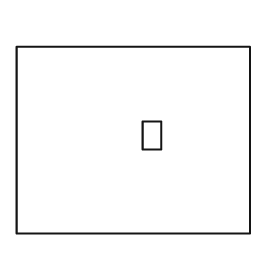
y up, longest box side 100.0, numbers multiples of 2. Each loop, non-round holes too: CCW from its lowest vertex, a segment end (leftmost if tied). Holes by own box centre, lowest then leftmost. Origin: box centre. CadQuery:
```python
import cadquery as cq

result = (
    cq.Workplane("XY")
    .moveTo(-50.0, -40.0)
    .lineTo(50.0, -40.0)
    .lineTo(50.0, 40.0)
    .lineTo(-50.0, 40.0)
    .close()
    .moveTo(4.0, -4.0)
    .lineTo(12.0, -4.0)
    .lineTo(12.0, 8.0)
    .lineTo(4.0, 8.0)
    .close()
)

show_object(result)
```